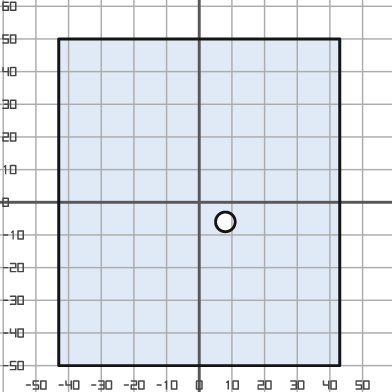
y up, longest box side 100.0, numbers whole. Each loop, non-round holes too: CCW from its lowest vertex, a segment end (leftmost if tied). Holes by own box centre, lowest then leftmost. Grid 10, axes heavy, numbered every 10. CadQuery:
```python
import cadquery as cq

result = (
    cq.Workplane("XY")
    .moveTo(-43.0, -50.0)
    .lineTo(43.0, -50.0)
    .lineTo(43.0, 50.0)
    .lineTo(-43.0, 50.0)
    .close()
    .moveTo(8.0, -6.0)
    .circle(3.0)
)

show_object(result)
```